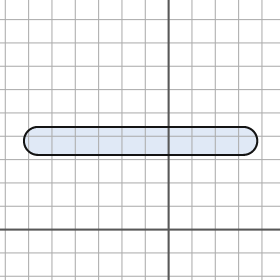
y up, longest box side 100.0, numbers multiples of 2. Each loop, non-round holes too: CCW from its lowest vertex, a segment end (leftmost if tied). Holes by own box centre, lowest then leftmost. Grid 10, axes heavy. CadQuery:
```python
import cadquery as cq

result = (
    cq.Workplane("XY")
    .moveTo(-56.0, 32.0)
    .lineTo(32.0, 32.0)
    .threePointArc((38.0, 38.0), (32.0, 44.0))
    .lineTo(-56.0, 44.0)
    .threePointArc((-62.0, 38.0), (-56.0, 32.0))
    .close()
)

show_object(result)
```